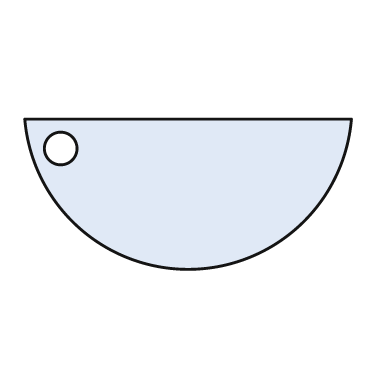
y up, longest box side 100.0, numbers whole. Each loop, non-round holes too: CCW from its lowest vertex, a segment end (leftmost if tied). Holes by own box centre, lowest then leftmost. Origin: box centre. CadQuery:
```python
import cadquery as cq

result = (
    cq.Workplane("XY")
    .moveTo(-50.0, 23.0)
    .threePointArc((0.0, -23.0), (50.0, 23.0))
    .close()
    .moveTo(-39.0, 14.0)
    .circle(5.0)
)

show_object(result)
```